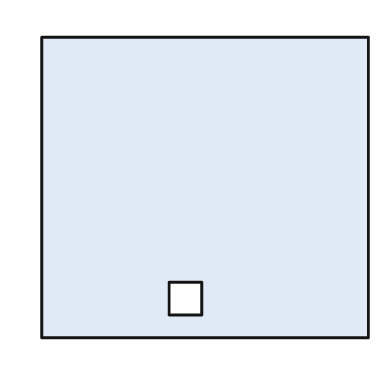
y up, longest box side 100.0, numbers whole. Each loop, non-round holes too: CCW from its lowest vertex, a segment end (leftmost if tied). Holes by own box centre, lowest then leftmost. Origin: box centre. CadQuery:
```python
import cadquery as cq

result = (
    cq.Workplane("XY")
    .moveTo(-50.0, -46.0)
    .lineTo(50.0, -46.0)
    .lineTo(50.0, 46.0)
    .lineTo(-50.0, 46.0)
    .close()
    .moveTo(-11.0, -39.0)
    .lineTo(-1.0, -39.0)
    .lineTo(-1.0, -29.0)
    .lineTo(-11.0, -29.0)
    .close()
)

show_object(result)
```